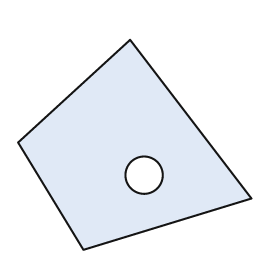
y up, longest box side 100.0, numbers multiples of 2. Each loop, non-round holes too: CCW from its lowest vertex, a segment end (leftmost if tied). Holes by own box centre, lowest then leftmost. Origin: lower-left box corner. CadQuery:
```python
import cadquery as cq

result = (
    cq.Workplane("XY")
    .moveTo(28.0, 0.0)
    .lineTo(100.0, 22.0)
    .lineTo(48.0, 90.0)
    .lineTo(0.0, 46.0)
    .close()
    .moveTo(54.0, 32.0)
    .circle(8.0)
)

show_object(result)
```